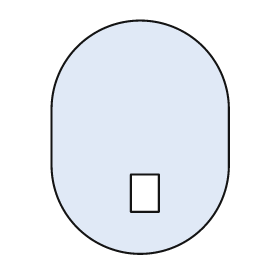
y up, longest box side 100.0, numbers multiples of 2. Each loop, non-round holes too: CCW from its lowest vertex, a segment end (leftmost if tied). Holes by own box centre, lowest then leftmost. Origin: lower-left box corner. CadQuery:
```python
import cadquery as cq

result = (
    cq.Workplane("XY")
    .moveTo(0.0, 38.0)
    .threePointArc((38.0, 0.0), (76.0, 38.0))
    .lineTo(76.0, 62.0)
    .threePointArc((38.0, 100.0), (0.0, 62.0))
    .close()
    .moveTo(34.0, 18.0)
    .lineTo(46.0, 18.0)
    .lineTo(46.0, 34.0)
    .lineTo(34.0, 34.0)
    .close()
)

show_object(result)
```